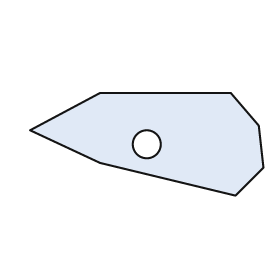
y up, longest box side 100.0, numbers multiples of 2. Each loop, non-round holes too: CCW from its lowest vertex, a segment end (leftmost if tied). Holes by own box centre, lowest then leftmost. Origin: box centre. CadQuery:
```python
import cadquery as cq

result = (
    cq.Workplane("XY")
    .moveTo(38.0, -22.0)
    .lineTo(50.0, -10.0)
    .lineTo(48.0, 8.0)
    .lineTo(36.0, 22.0)
    .lineTo(-20.0, 22.0)
    .lineTo(-50.0, 6.0)
    .lineTo(-20.0, -8.0)
    .close()
    .moveTo(0.0, 0.0)
    .circle(6.0)
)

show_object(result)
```